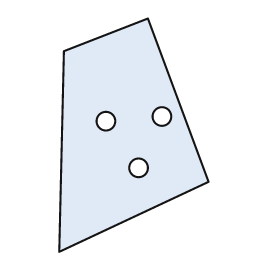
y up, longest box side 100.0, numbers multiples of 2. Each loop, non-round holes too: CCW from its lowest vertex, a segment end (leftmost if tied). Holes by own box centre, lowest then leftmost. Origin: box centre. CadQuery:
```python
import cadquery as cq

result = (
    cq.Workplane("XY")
    .moveTo(-32.0, -50.0)
    .lineTo(32.0, -20.0)
    .lineTo(6.0, 50.0)
    .lineTo(-30.0, 36.0)
    .close()
    .moveTo(2.0, -14.0)
    .circle(4.0)
    .moveTo(-12.0, 6.0)
    .circle(4.0)
    .moveTo(12.0, 8.0)
    .circle(4.0)
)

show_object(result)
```